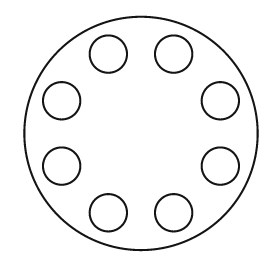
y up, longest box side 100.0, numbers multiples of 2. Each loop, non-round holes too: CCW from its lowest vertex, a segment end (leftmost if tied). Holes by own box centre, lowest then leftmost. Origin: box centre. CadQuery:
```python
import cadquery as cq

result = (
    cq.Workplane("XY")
    .moveTo(0.0, 0.0)
    .circle(50.0)
    .moveTo(-14.0, -34.0)
    .circle(8.0)
    .moveTo(14.0, -34.0)
    .circle(8.0)
    .moveTo(-34.0, -14.0)
    .circle(8.0)
    .moveTo(34.0, -14.0)
    .circle(8.0)
    .moveTo(-34.0, 14.0)
    .circle(8.0)
    .moveTo(34.0, 14.0)
    .circle(8.0)
    .moveTo(-14.0, 34.0)
    .circle(8.0)
    .moveTo(14.0, 34.0)
    .circle(8.0)
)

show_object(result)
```